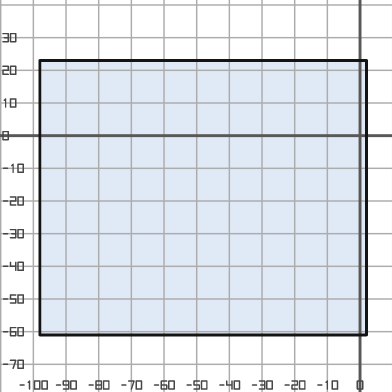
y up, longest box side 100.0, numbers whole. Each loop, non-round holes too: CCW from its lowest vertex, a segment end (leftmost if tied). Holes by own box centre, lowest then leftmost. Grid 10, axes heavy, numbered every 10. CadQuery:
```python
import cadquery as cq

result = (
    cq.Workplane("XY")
    .moveTo(-98.0, -61.0)
    .lineTo(2.0, -61.0)
    .lineTo(2.0, 23.0)
    .lineTo(-98.0, 23.0)
    .close()
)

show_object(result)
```